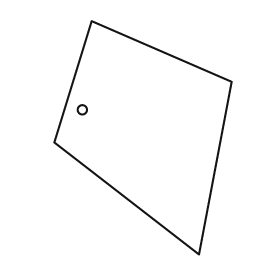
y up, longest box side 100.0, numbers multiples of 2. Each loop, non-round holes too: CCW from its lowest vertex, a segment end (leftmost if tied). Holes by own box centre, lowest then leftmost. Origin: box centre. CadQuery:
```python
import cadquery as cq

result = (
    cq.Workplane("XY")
    .moveTo(24.0, -50.0)
    .lineTo(38.0, 24.0)
    .lineTo(-22.0, 50.0)
    .lineTo(-38.0, -2.0)
    .close()
    .moveTo(-26.0, 12.0)
    .circle(2.0)
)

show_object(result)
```